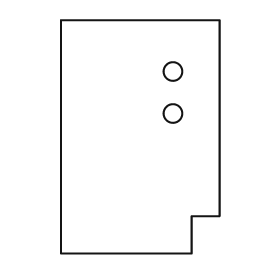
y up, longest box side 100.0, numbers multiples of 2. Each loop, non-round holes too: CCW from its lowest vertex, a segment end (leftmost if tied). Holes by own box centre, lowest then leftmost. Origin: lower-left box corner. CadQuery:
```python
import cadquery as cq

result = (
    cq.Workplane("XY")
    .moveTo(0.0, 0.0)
    .lineTo(56.0, 0.0)
    .lineTo(56.0, 16.0)
    .lineTo(68.0, 16.0)
    .lineTo(68.0, 100.0)
    .lineTo(0.0, 100.0)
    .close()
    .moveTo(48.0, 60.0)
    .circle(4.0)
    .moveTo(48.0, 78.0)
    .circle(4.0)
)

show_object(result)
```